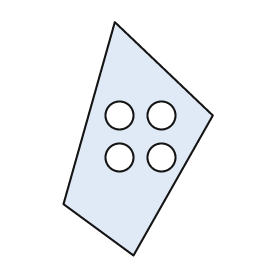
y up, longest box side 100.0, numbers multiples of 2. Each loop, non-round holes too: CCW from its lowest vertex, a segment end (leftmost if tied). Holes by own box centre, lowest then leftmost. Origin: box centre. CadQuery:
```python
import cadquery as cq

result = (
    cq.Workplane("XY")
    .moveTo(-2.0, -50.0)
    .lineTo(32.0, 10.0)
    .lineTo(-10.0, 50.0)
    .lineTo(-32.0, -28.0)
    .close()
    .moveTo(-8.0, -8.0)
    .circle(6.0)
    .moveTo(10.0, -8.0)
    .circle(6.0)
    .moveTo(-8.0, 10.0)
    .circle(6.0)
    .moveTo(10.0, 10.0)
    .circle(6.0)
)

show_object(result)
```